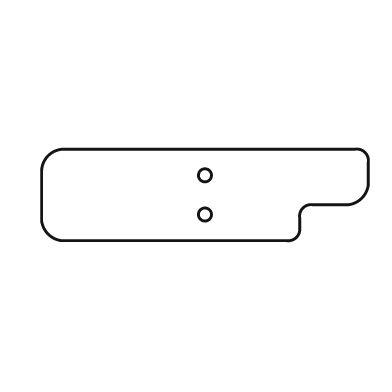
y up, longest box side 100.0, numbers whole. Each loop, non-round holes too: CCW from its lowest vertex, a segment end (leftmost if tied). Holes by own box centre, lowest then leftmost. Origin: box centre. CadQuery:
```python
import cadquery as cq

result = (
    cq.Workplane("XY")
    .moveTo(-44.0, -14.0)
    .lineTo(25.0, -14.0)
    .threePointArc((28.0, -13.0), (29.0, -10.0))
    .lineTo(29.0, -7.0)
    .threePointArc((30.0, -4.0), (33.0, -3.0))
    .lineTo(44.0, -3.0)
    .threePointArc((48.0, -1.0), (50.0, 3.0))
    .lineTo(50.0, 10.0)
    .threePointArc((49.0, 13.0), (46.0, 14.0))
    .lineTo(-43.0, 14.0)
    .threePointArc((-48.0, 12.0), (-50.0, 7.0))
    .lineTo(-50.0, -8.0)
    .threePointArc((-48.0, -12.0), (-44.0, -14.0))
    .close()
    .moveTo(0.0, -6.0)
    .circle(2.0)
    .moveTo(0.0, 6.0)
    .circle(2.0)
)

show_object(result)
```